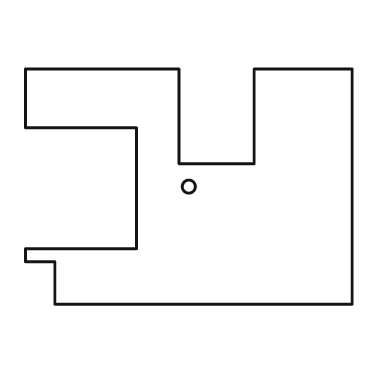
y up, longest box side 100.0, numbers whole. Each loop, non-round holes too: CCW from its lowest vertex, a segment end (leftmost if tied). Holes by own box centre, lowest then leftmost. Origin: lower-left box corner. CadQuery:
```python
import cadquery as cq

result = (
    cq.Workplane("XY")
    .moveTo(9.0, 0.0)
    .lineTo(100.0, 0.0)
    .lineTo(100.0, 72.0)
    .lineTo(70.0, 72.0)
    .lineTo(70.0, 43.0)
    .lineTo(47.0, 43.0)
    .lineTo(47.0, 72.0)
    .lineTo(0.0, 72.0)
    .lineTo(0.0, 54.0)
    .lineTo(34.0, 54.0)
    .lineTo(34.0, 17.0)
    .lineTo(0.0, 17.0)
    .lineTo(0.0, 13.0)
    .lineTo(9.0, 13.0)
    .close()
    .moveTo(50.0, 36.0)
    .circle(2.0)
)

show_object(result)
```